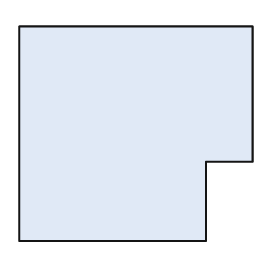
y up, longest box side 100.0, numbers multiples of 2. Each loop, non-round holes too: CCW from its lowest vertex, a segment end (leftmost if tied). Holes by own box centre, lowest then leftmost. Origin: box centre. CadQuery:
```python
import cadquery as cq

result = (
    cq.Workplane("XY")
    .moveTo(-50.0, -46.0)
    .lineTo(30.0, -46.0)
    .lineTo(30.0, -12.0)
    .lineTo(50.0, -12.0)
    .lineTo(50.0, 46.0)
    .lineTo(-50.0, 46.0)
    .close()
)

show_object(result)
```